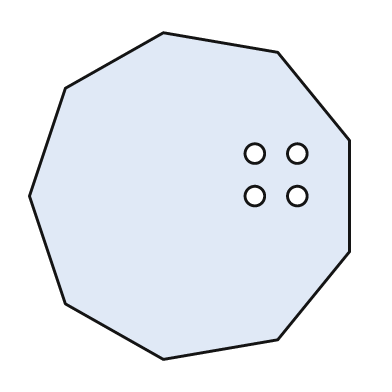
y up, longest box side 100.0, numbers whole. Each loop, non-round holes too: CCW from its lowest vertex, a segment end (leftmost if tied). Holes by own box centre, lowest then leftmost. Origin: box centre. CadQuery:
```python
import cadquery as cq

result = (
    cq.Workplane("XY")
    .moveTo(-8.0, -50.0)
    .lineTo(27.0, -44.0)
    .lineTo(49.0, -17.0)
    .lineTo(49.0, 17.0)
    .lineTo(27.0, 44.0)
    .lineTo(-8.0, 50.0)
    .lineTo(-38.0, 33.0)
    .lineTo(-49.0, 0.0)
    .lineTo(-38.0, -33.0)
    .close()
    .moveTo(20.0, 0.0)
    .circle(3.0)
    .moveTo(33.0, 0.0)
    .circle(3.0)
    .moveTo(20.0, 13.0)
    .circle(3.0)
    .moveTo(33.0, 13.0)
    .circle(3.0)
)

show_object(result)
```